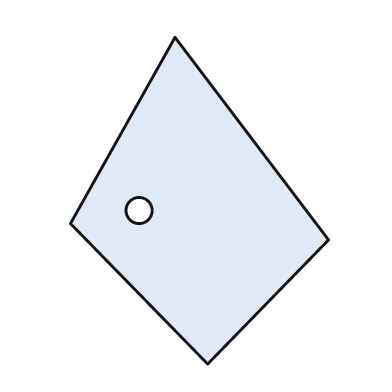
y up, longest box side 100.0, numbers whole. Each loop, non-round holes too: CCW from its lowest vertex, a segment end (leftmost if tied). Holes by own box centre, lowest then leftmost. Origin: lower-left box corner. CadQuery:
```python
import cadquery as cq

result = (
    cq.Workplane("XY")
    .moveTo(42.0, 0.0)
    .lineTo(79.0, 38.0)
    .lineTo(32.0, 100.0)
    .lineTo(0.0, 43.0)
    .close()
    .moveTo(21.0, 47.0)
    .circle(4.0)
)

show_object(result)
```